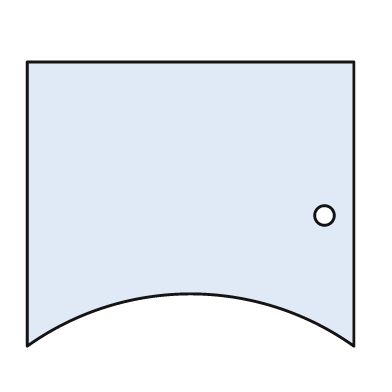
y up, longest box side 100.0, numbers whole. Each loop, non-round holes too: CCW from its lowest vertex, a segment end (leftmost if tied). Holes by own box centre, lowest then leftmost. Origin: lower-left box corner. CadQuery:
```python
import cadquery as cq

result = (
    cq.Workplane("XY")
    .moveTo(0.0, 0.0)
    .threePointArc((50.0, 16.0), (100.0, 0.0))
    .lineTo(100.0, 87.0)
    .lineTo(0.0, 87.0)
    .close()
    .moveTo(91.0, 40.0)
    .circle(3.0)
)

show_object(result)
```